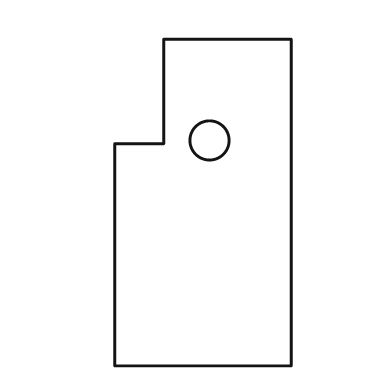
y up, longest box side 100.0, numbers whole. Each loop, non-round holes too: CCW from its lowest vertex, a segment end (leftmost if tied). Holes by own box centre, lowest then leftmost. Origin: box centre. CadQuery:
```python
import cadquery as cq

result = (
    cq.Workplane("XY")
    .moveTo(-27.0, -50.0)
    .lineTo(27.0, -50.0)
    .lineTo(27.0, 50.0)
    .lineTo(-12.0, 50.0)
    .lineTo(-12.0, 18.0)
    .lineTo(-27.0, 18.0)
    .close()
    .moveTo(2.0, 19.0)
    .circle(6.0)
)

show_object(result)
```